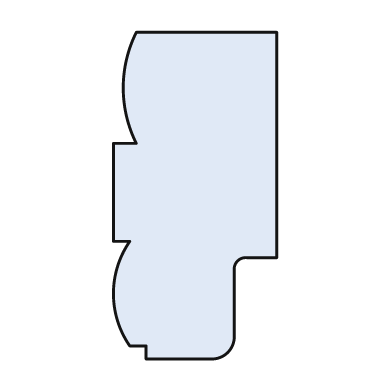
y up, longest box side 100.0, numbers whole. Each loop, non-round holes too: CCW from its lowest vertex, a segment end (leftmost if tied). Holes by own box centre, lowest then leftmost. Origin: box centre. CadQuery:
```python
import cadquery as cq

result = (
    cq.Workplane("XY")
    .moveTo(-15.0, -50.0)
    .lineTo(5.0, -50.0)
    .threePointArc((10.0, -48.0), (12.0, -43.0))
    .lineTo(12.0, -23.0)
    .threePointArc((13.0, -20.0), (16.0, -19.0))
    .lineTo(25.0, -19.0)
    .lineTo(25.0, 50.0)
    .lineTo(-18.0, 50.0)
    .threePointArc((-22.0, 33.0), (-18.0, 16.0))
    .lineTo(-25.0, 16.0)
    .lineTo(-25.0, -14.0)
    .lineTo(-20.0, -14.0)
    .threePointArc((-25.0, -30.0), (-20.0, -46.0))
    .lineTo(-15.0, -46.0)
    .close()
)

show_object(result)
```